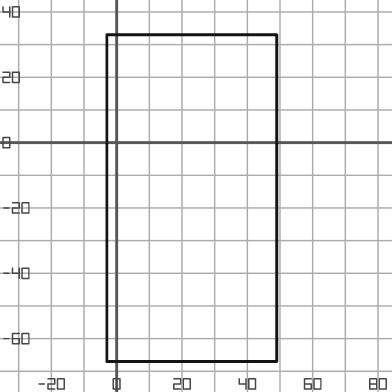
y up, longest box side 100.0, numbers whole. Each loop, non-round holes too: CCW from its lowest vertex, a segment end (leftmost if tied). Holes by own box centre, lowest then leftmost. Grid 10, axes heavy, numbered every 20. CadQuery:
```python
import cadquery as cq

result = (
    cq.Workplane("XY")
    .moveTo(-3.0, -67.0)
    .lineTo(49.0, -67.0)
    .lineTo(49.0, 33.0)
    .lineTo(-3.0, 33.0)
    .close()
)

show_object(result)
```